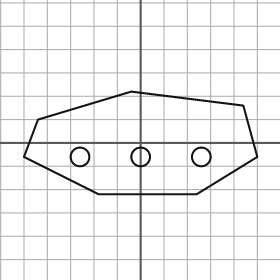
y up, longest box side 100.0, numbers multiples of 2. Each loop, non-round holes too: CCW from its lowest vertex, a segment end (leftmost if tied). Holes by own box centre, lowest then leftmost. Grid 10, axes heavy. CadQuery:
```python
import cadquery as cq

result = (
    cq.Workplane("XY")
    .moveTo(-18.0, -22.0)
    .lineTo(24.0, -22.0)
    .lineTo(50.0, -6.0)
    .lineTo(44.0, 16.0)
    .lineTo(-4.0, 22.0)
    .lineTo(-44.0, 10.0)
    .lineTo(-50.0, -6.0)
    .close()
    .moveTo(-26.0, -6.0)
    .circle(4.0)
    .moveTo(0.0, -6.0)
    .circle(4.0)
    .moveTo(26.0, -6.0)
    .circle(4.0)
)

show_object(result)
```